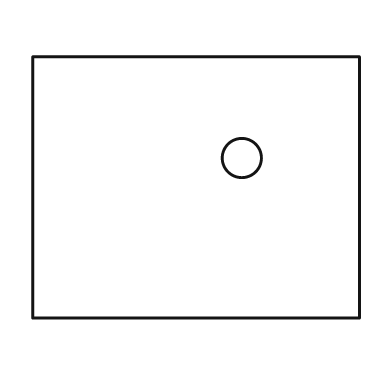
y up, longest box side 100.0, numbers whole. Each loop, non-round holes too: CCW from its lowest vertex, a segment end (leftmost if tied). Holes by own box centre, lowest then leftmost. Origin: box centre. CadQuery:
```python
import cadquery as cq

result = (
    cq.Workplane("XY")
    .moveTo(-50.0, -40.0)
    .lineTo(50.0, -40.0)
    .lineTo(50.0, 40.0)
    .lineTo(-50.0, 40.0)
    .close()
    .moveTo(14.0, 9.0)
    .circle(6.0)
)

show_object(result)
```